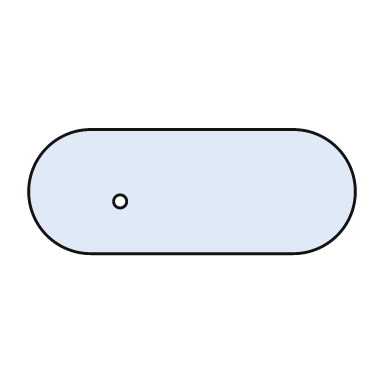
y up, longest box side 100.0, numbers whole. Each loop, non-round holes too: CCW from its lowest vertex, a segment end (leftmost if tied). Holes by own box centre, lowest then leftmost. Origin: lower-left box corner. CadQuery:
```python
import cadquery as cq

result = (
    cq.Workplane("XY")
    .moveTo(19.0, 0.0)
    .lineTo(81.0, 0.0)
    .threePointArc((100.0, 19.0), (81.0, 38.0))
    .lineTo(19.0, 38.0)
    .threePointArc((0.0, 19.0), (19.0, 0.0))
    .close()
    .moveTo(28.0, 16.0)
    .circle(2.0)
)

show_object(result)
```